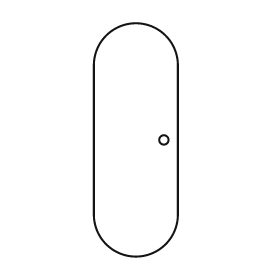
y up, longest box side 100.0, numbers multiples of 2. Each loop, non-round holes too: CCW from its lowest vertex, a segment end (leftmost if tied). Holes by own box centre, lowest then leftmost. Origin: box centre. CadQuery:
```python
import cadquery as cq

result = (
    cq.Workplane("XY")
    .moveTo(-18.0, -32.0)
    .threePointArc((0.0, -50.0), (18.0, -32.0))
    .lineTo(18.0, 32.0)
    .threePointArc((0.0, 50.0), (-18.0, 32.0))
    .close()
    .moveTo(12.0, 0.0)
    .circle(2.0)
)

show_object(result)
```